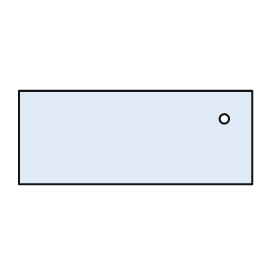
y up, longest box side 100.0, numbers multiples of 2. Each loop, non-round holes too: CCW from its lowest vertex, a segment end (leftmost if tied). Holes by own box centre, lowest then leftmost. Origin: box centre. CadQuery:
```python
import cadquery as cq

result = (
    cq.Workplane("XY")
    .moveTo(-50.0, -20.0)
    .lineTo(50.0, -20.0)
    .lineTo(50.0, 20.0)
    .lineTo(-50.0, 20.0)
    .close()
    .moveTo(38.0, 8.0)
    .circle(2.0)
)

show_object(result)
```